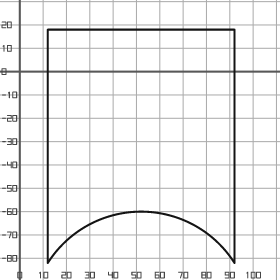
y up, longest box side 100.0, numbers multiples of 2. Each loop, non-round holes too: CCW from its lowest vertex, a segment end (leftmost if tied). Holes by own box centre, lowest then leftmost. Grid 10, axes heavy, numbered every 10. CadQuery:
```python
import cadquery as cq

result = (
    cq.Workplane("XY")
    .moveTo(12.0, -82.0)
    .threePointArc((52.0, -60.0), (92.0, -82.0))
    .lineTo(92.0, 18.0)
    .lineTo(12.0, 18.0)
    .close()
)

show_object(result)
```